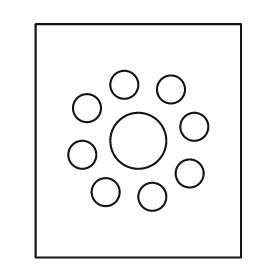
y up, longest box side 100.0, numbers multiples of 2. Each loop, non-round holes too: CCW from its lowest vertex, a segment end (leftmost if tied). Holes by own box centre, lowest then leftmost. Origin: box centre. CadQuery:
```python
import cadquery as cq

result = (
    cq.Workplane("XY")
    .moveTo(-44.0, -50.0)
    .lineTo(44.0, -50.0)
    .lineTo(44.0, 50.0)
    .lineTo(-44.0, 50.0)
    .close()
    .moveTo(6.0, -24.0)
    .circle(6.0)
    .moveTo(-14.0, -22.0)
    .circle(6.0)
    .moveTo(22.0, -14.0)
    .circle(6.0)
    .moveTo(-24.0, -6.0)
    .circle(6.0)
    .moveTo(0.0, 0.0)
    .circle(12.0)
    .moveTo(24.0, 6.0)
    .circle(6.0)
    .moveTo(-22.0, 14.0)
    .circle(6.0)
    .moveTo(14.0, 22.0)
    .circle(6.0)
    .moveTo(-6.0, 24.0)
    .circle(6.0)
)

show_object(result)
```